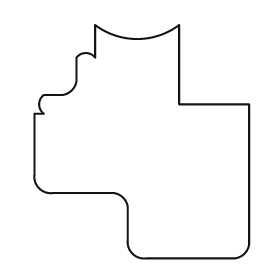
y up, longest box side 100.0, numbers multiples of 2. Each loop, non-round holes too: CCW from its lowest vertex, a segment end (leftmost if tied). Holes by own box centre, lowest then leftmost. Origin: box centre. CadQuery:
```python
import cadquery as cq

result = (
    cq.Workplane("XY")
    .moveTo(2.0, -50.0)
    .lineTo(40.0, -50.0)
    .threePointArc((44.0, -48.0), (46.0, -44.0))
    .lineTo(46.0, 16.0)
    .lineTo(16.0, 16.0)
    .lineTo(16.0, 50.0)
    .threePointArc((-2.0, 44.0), (-20.0, 50.0))
    .lineTo(-20.0, 36.0)
    .threePointArc((-24.0, 38.0), (-28.0, 36.0))
    .lineTo(-28.0, 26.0)
    .threePointArc((-30.0, 22.0), (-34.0, 20.0))
    .lineTo(-42.0, 20.0)
    .threePointArc((-44.0, 16.0), (-42.0, 12.0))
    .lineTo(-46.0, 12.0)
    .lineTo(-46.0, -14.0)
    .threePointArc((-44.0, -20.0), (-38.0, -22.0))
    .lineTo(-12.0, -22.0)
    .threePointArc((-8.0, -24.0), (-6.0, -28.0))
    .lineTo(-6.0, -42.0)
    .threePointArc((-4.0, -48.0), (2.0, -50.0))
    .close()
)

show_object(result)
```